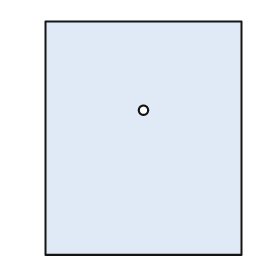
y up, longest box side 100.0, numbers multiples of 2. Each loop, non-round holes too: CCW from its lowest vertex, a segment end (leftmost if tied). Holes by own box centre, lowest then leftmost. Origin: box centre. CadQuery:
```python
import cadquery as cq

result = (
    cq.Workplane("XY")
    .moveTo(-42.0, -50.0)
    .lineTo(42.0, -50.0)
    .lineTo(42.0, 50.0)
    .lineTo(-42.0, 50.0)
    .close()
    .moveTo(0.0, 12.0)
    .circle(2.0)
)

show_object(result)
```